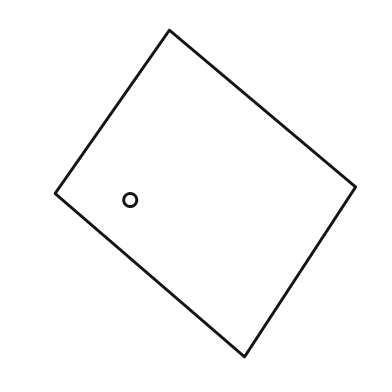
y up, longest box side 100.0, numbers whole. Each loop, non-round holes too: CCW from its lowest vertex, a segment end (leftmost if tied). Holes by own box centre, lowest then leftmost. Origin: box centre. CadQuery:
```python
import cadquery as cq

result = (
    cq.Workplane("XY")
    .moveTo(12.0, -50.0)
    .lineTo(46.0, 2.0)
    .lineTo(-11.0, 50.0)
    .lineTo(-46.0, 0.0)
    .close()
    .moveTo(-23.0, -2.0)
    .circle(2.0)
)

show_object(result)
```